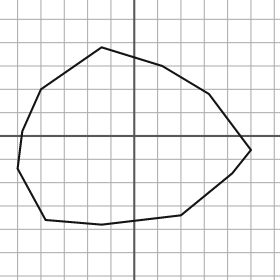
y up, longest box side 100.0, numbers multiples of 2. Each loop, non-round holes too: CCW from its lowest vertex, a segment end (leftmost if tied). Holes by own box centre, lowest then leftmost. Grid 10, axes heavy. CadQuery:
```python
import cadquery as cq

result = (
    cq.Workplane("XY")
    .moveTo(-14.0, -38.0)
    .lineTo(20.0, -34.0)
    .lineTo(42.0, -16.0)
    .lineTo(50.0, -6.0)
    .lineTo(32.0, 18.0)
    .lineTo(12.0, 30.0)
    .lineTo(-14.0, 38.0)
    .lineTo(-40.0, 20.0)
    .lineTo(-48.0, 2.0)
    .lineTo(-50.0, -14.0)
    .lineTo(-38.0, -36.0)
    .close()
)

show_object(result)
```